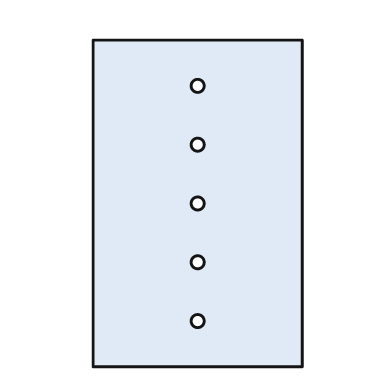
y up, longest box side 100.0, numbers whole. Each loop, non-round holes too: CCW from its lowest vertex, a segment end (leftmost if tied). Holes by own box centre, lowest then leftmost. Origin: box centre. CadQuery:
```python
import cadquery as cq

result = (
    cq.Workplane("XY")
    .moveTo(-32.0, -50.0)
    .lineTo(32.0, -50.0)
    .lineTo(32.0, 50.0)
    .lineTo(-32.0, 50.0)
    .close()
    .moveTo(0.0, -36.0)
    .circle(2.0)
    .moveTo(0.0, -18.0)
    .circle(2.0)
    .moveTo(0.0, 0.0)
    .circle(2.0)
    .moveTo(0.0, 18.0)
    .circle(2.0)
    .moveTo(0.0, 36.0)
    .circle(2.0)
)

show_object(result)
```